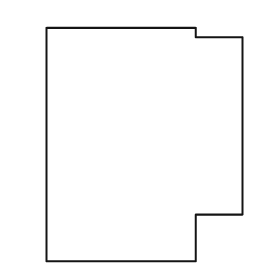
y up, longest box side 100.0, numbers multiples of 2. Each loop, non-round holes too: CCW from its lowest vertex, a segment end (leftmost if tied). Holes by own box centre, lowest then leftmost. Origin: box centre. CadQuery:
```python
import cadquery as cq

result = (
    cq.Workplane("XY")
    .moveTo(-42.0, -50.0)
    .lineTo(22.0, -50.0)
    .lineTo(22.0, -30.0)
    .lineTo(42.0, -30.0)
    .lineTo(42.0, 46.0)
    .lineTo(22.0, 46.0)
    .lineTo(22.0, 50.0)
    .lineTo(-42.0, 50.0)
    .close()
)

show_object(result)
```